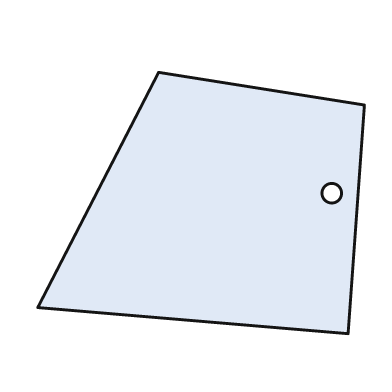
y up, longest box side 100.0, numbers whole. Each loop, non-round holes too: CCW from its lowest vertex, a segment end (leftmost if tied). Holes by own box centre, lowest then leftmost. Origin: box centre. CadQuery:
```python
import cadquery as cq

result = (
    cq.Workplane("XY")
    .moveTo(45.0, -40.0)
    .lineTo(50.0, 30.0)
    .lineTo(-13.0, 40.0)
    .lineTo(-50.0, -32.0)
    .close()
    .moveTo(40.0, 3.0)
    .circle(3.0)
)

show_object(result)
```